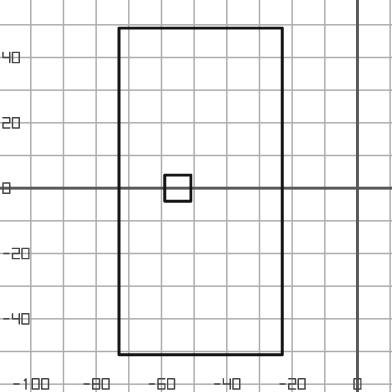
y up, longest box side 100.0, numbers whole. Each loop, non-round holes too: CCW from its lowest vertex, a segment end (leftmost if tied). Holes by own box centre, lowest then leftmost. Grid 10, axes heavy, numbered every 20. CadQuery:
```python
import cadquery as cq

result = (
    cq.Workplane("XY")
    .moveTo(-73.0, -51.0)
    .lineTo(-23.0, -51.0)
    .lineTo(-23.0, 49.0)
    .lineTo(-73.0, 49.0)
    .close()
    .moveTo(-59.0, -4.0)
    .lineTo(-51.0, -4.0)
    .lineTo(-51.0, 4.0)
    .lineTo(-59.0, 4.0)
    .close()
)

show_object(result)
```